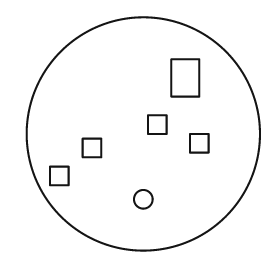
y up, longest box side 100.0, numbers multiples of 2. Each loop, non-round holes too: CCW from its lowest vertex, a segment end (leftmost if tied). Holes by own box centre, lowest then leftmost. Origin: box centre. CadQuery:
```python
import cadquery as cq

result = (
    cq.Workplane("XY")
    .moveTo(0.0, 0.0)
    .circle(50.0)
    .moveTo(0.0, -28.0)
    .circle(4.0)
    .moveTo(-40.0, -22.0)
    .lineTo(-32.0, -22.0)
    .lineTo(-32.0, -14.0)
    .lineTo(-40.0, -14.0)
    .close()
    .moveTo(-26.0, -10.0)
    .lineTo(-18.0, -10.0)
    .lineTo(-18.0, -2.0)
    .lineTo(-26.0, -2.0)
    .close()
    .moveTo(20.0, -8.0)
    .lineTo(28.0, -8.0)
    .lineTo(28.0, 0.0)
    .lineTo(20.0, 0.0)
    .close()
    .moveTo(2.0, 0.0)
    .lineTo(10.0, 0.0)
    .lineTo(10.0, 8.0)
    .lineTo(2.0, 8.0)
    .close()
    .moveTo(12.0, 16.0)
    .lineTo(24.0, 16.0)
    .lineTo(24.0, 32.0)
    .lineTo(12.0, 32.0)
    .close()
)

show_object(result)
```